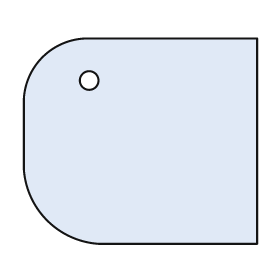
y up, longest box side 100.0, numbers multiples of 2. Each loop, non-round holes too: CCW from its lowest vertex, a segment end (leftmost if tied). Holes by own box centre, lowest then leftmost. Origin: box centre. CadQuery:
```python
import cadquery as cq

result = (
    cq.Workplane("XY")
    .moveTo(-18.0, -44.0)
    .lineTo(50.0, -44.0)
    .lineTo(50.0, 44.0)
    .lineTo(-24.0, 44.0)
    .threePointArc((-42.0, 36.0), (-50.0, 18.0))
    .lineTo(-50.0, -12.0)
    .threePointArc((-40.0, -34.0), (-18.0, -44.0))
    .close()
    .moveTo(-22.0, 26.0)
    .circle(4.0)
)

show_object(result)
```